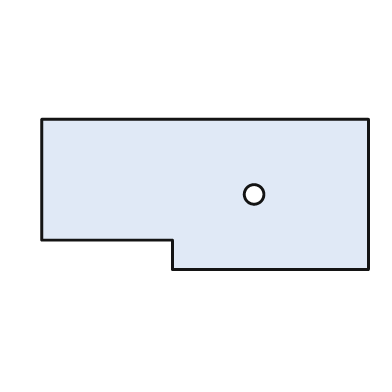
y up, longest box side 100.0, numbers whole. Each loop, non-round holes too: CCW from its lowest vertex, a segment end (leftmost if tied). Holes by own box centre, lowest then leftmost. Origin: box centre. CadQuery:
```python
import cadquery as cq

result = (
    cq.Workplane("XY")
    .moveTo(-10.0, -23.0)
    .lineTo(50.0, -23.0)
    .lineTo(50.0, 23.0)
    .lineTo(-50.0, 23.0)
    .lineTo(-50.0, -14.0)
    .lineTo(-10.0, -14.0)
    .close()
    .moveTo(15.0, 0.0)
    .circle(3.0)
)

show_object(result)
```